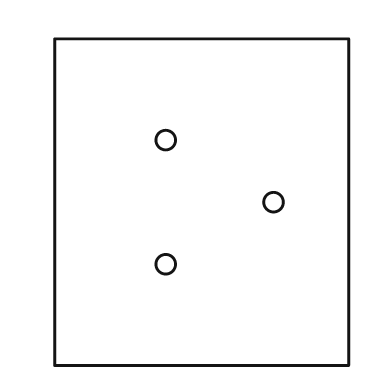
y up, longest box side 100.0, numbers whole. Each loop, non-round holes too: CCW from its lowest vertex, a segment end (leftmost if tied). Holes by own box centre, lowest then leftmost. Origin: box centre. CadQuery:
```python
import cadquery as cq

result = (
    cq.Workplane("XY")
    .moveTo(-45.0, -50.0)
    .lineTo(45.0, -50.0)
    .lineTo(45.0, 50.0)
    .lineTo(-45.0, 50.0)
    .close()
    .moveTo(-11.0, -19.0)
    .circle(3.0)
    .moveTo(22.0, 0.0)
    .circle(3.0)
    .moveTo(-11.0, 19.0)
    .circle(3.0)
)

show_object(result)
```